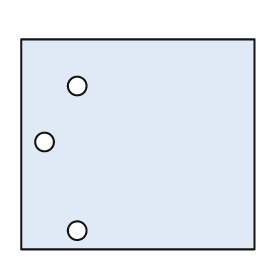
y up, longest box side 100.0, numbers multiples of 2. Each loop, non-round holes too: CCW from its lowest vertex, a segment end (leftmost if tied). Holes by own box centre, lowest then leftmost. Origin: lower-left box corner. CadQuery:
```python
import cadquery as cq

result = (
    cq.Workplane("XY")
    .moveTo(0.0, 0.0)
    .lineTo(100.0, 0.0)
    .lineTo(100.0, 90.0)
    .lineTo(0.0, 90.0)
    .close()
    .moveTo(24.0, 8.0)
    .circle(4.0)
    .moveTo(10.0, 46.0)
    .circle(4.0)
    .moveTo(24.0, 70.0)
    .circle(4.0)
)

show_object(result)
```